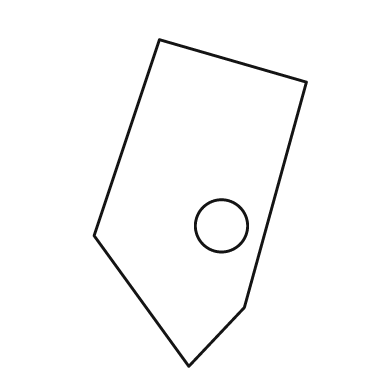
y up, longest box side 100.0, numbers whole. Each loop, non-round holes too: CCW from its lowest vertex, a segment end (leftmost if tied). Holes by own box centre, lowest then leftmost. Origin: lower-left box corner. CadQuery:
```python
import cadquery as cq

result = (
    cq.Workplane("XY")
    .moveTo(29.0, 0.0)
    .lineTo(46.0, 18.0)
    .lineTo(65.0, 87.0)
    .lineTo(20.0, 100.0)
    .lineTo(0.0, 40.0)
    .close()
    .moveTo(39.0, 43.0)
    .circle(8.0)
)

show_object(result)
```